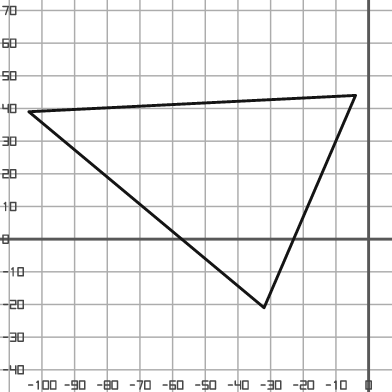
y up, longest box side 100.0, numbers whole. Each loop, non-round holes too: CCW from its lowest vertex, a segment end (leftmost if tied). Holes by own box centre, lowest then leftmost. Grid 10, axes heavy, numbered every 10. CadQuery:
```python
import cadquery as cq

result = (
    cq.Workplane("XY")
    .moveTo(-32.0, -21.0)
    .lineTo(-4.0, 44.0)
    .lineTo(-104.0, 39.0)
    .close()
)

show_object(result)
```